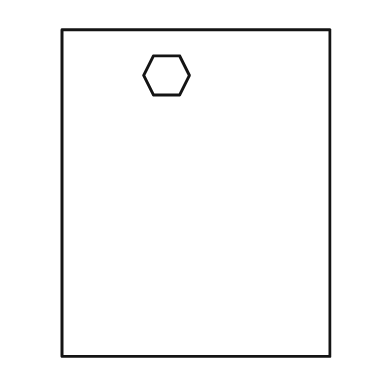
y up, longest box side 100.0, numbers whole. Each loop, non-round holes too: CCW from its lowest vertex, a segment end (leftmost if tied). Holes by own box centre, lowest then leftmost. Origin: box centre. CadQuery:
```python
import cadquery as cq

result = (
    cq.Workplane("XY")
    .moveTo(-41.0, -50.0)
    .lineTo(41.0, -50.0)
    .lineTo(41.0, 50.0)
    .lineTo(-41.0, 50.0)
    .close()
    .moveTo(-13.0, 30.0)
    .lineTo(-5.0, 30.0)
    .lineTo(-2.0, 36.0)
    .lineTo(-5.0, 42.0)
    .lineTo(-13.0, 42.0)
    .lineTo(-16.0, 36.0)
    .close()
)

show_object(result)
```